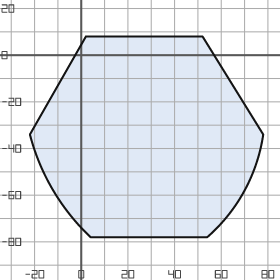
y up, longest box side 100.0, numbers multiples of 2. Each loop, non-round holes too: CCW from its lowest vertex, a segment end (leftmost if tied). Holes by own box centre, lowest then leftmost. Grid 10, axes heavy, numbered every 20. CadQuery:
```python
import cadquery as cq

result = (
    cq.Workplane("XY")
    .moveTo(4.0, -78.0)
    .lineTo(54.0, -78.0)
    .threePointArc((70.0, -58.0), (78.0, -34.0))
    .lineTo(52.0, 8.0)
    .lineTo(2.0, 8.0)
    .lineTo(-22.0, -34.0)
    .threePointArc((-12.0, -58.0), (4.0, -78.0))
    .close()
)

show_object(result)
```